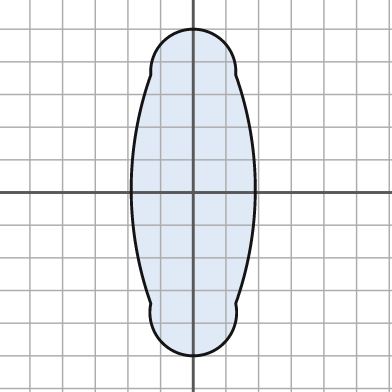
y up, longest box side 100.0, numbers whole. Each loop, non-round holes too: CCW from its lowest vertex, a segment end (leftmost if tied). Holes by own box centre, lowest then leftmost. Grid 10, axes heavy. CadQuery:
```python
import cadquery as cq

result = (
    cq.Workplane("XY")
    .moveTo(-13.0, -34.0)
    .threePointArc((0.0, -50.0), (13.0, -34.0))
    .threePointArc((19.0, 1.0), (13.0, 36.0))
    .threePointArc((0.0, 50.0), (-13.0, 36.0))
    .threePointArc((-19.0, 1.0), (-13.0, -34.0))
    .close()
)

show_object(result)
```